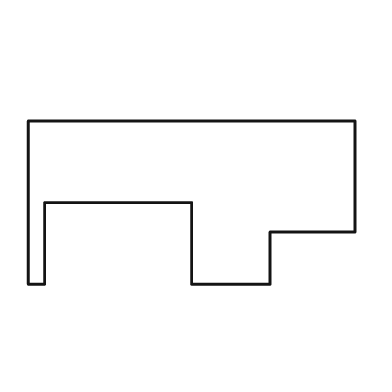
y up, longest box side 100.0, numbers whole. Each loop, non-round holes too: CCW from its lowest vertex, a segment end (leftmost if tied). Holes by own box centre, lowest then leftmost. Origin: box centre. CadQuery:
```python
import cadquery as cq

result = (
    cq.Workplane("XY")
    .moveTo(-50.0, -25.0)
    .lineTo(-45.0, -25.0)
    .lineTo(-45.0, 0.0)
    .lineTo(0.0, 0.0)
    .lineTo(0.0, -25.0)
    .lineTo(24.0, -25.0)
    .lineTo(24.0, -9.0)
    .lineTo(50.0, -9.0)
    .lineTo(50.0, 25.0)
    .lineTo(-50.0, 25.0)
    .close()
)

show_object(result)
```